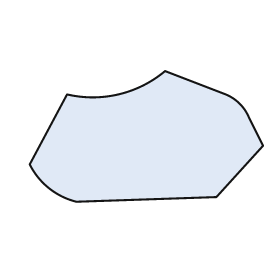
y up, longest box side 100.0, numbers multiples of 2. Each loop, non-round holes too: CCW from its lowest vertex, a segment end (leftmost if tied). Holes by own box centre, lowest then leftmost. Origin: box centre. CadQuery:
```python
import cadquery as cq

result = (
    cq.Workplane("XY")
    .moveTo(-30.0, -28.0)
    .lineTo(30.0, -26.0)
    .lineTo(50.0, -4.0)
    .lineTo(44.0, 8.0)
    .threePointArc((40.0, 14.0), (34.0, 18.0))
    .lineTo(8.0, 28.0)
    .threePointArc((-12.0, 18.0), (-34.0, 18.0))
    .lineTo(-50.0, -12.0)
    .threePointArc((-42.0, -22.0), (-30.0, -28.0))
    .close()
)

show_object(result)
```